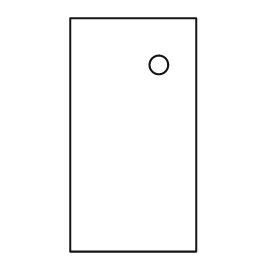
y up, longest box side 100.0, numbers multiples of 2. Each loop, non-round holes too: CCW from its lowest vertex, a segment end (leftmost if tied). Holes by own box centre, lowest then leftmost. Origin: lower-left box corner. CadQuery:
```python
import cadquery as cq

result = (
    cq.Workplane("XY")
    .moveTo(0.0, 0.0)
    .lineTo(54.0, 0.0)
    .lineTo(54.0, 100.0)
    .lineTo(0.0, 100.0)
    .close()
    .moveTo(38.0, 80.0)
    .circle(4.0)
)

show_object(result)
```